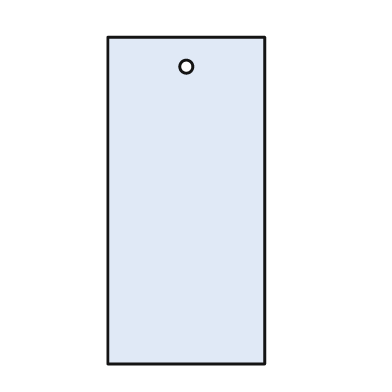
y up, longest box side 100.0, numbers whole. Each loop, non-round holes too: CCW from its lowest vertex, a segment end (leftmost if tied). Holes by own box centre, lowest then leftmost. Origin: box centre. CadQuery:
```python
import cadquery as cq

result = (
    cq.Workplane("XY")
    .moveTo(-24.0, -50.0)
    .lineTo(24.0, -50.0)
    .lineTo(24.0, 50.0)
    .lineTo(-24.0, 50.0)
    .close()
    .moveTo(0.0, 41.0)
    .circle(2.0)
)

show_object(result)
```